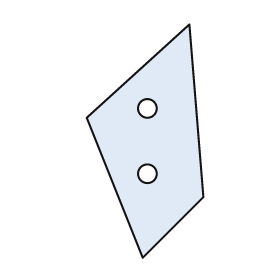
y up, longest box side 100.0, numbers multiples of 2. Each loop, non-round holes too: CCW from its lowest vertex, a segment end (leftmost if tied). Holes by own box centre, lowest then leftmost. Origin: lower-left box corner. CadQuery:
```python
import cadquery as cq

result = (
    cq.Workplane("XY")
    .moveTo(24.0, 0.0)
    .lineTo(50.0, 26.0)
    .lineTo(44.0, 100.0)
    .lineTo(0.0, 60.0)
    .close()
    .moveTo(26.0, 36.0)
    .circle(4.0)
    .moveTo(26.0, 64.0)
    .circle(4.0)
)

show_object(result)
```